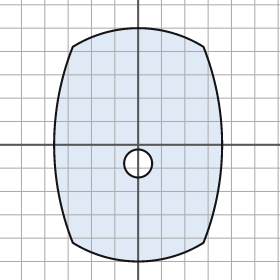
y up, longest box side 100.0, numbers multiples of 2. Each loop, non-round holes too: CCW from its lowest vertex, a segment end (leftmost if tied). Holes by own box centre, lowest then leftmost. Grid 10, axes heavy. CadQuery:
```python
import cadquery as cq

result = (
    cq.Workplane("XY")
    .moveTo(-28.0, -42.0)
    .threePointArc((0.0, -50.0), (28.0, -42.0))
    .threePointArc((36.0, 0.0), (28.0, 42.0))
    .threePointArc((0.0, 50.0), (-28.0, 42.0))
    .threePointArc((-36.0, 0.0), (-28.0, -42.0))
    .close()
    .moveTo(0.0, -8.0)
    .circle(6.0)
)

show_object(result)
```